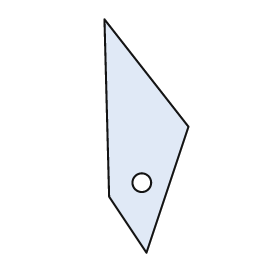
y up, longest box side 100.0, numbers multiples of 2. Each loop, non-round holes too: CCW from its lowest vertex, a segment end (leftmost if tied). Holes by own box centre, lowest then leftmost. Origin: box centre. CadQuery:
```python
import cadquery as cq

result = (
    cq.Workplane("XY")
    .moveTo(0.0, -50.0)
    .lineTo(18.0, 4.0)
    .lineTo(-18.0, 50.0)
    .lineTo(-16.0, -26.0)
    .close()
    .moveTo(-2.0, -20.0)
    .circle(4.0)
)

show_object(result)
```